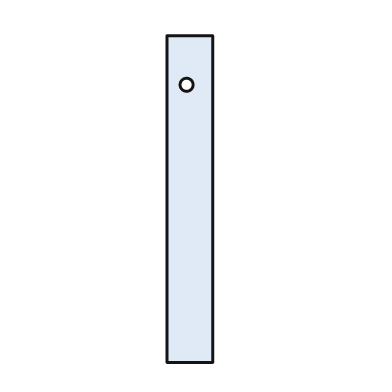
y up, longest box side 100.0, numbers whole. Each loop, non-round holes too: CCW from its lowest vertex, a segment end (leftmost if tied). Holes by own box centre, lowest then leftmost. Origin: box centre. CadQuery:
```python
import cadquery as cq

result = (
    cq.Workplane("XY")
    .moveTo(-7.0, -50.0)
    .lineTo(7.0, -50.0)
    .lineTo(7.0, 50.0)
    .lineTo(-7.0, 50.0)
    .close()
    .moveTo(-1.0, 35.0)
    .circle(2.0)
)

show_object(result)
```